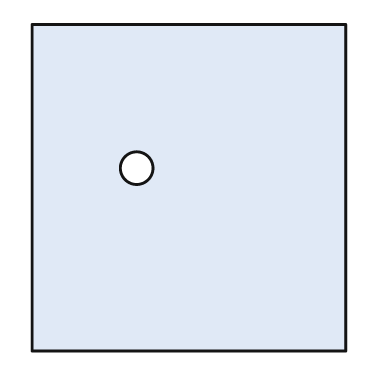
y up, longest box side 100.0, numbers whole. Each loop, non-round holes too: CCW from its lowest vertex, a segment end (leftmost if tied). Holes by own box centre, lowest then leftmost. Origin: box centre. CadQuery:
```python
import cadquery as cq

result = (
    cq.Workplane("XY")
    .moveTo(-48.0, -50.0)
    .lineTo(48.0, -50.0)
    .lineTo(48.0, 50.0)
    .lineTo(-48.0, 50.0)
    .close()
    .moveTo(-16.0, 6.0)
    .circle(5.0)
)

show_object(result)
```